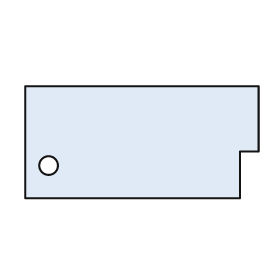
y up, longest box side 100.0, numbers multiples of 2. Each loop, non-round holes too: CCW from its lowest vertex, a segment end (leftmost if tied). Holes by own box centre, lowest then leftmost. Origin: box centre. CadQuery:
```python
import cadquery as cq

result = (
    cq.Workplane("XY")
    .moveTo(-50.0, -24.0)
    .lineTo(42.0, -24.0)
    .lineTo(42.0, -4.0)
    .lineTo(50.0, -4.0)
    .lineTo(50.0, 24.0)
    .lineTo(-50.0, 24.0)
    .close()
    .moveTo(-40.0, -10.0)
    .circle(4.0)
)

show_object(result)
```